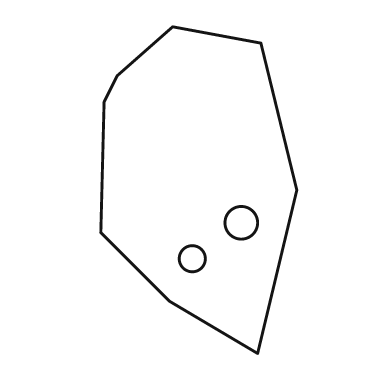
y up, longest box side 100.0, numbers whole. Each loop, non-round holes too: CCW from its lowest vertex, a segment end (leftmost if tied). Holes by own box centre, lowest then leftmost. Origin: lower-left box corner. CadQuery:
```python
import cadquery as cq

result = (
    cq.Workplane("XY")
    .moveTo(48.0, 0.0)
    .lineTo(60.0, 50.0)
    .lineTo(49.0, 95.0)
    .lineTo(22.0, 100.0)
    .lineTo(5.0, 85.0)
    .lineTo(1.0, 77.0)
    .lineTo(0.0, 37.0)
    .lineTo(21.0, 16.0)
    .close()
    .moveTo(28.0, 29.0)
    .circle(4.0)
    .moveTo(43.0, 40.0)
    .circle(5.0)
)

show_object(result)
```